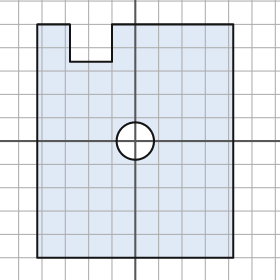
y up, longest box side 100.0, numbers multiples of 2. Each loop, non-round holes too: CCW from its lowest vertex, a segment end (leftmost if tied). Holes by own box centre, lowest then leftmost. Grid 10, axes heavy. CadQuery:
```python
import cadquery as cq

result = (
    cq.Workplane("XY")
    .moveTo(-42.0, -50.0)
    .lineTo(42.0, -50.0)
    .lineTo(42.0, 50.0)
    .lineTo(-10.0, 50.0)
    .lineTo(-10.0, 34.0)
    .lineTo(-28.0, 34.0)
    .lineTo(-28.0, 50.0)
    .lineTo(-42.0, 50.0)
    .close()
    .moveTo(0.0, 0.0)
    .circle(8.0)
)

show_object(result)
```